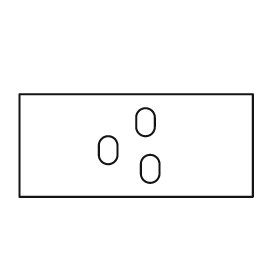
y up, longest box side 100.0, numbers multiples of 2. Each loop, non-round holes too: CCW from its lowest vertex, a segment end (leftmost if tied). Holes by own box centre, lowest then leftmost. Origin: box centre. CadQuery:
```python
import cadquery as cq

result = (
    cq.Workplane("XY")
    .moveTo(-50.0, -22.0)
    .lineTo(50.0, -22.0)
    .lineTo(50.0, 22.0)
    .lineTo(-50.0, 22.0)
    .close()
    .moveTo(2.0, -12.0)
    .threePointArc((6.0, -16.0), (10.0, -12.0))
    .lineTo(10.0, -8.0)
    .threePointArc((6.0, -4.0), (2.0, -8.0))
    .close()
    .moveTo(-16.0, -4.0)
    .threePointArc((-12.0, -8.0), (-8.0, -4.0))
    .lineTo(-8.0, 0.0)
    .threePointArc((-12.0, 4.0), (-16.0, 0.0))
    .close()
    .moveTo(0.0, 8.0)
    .threePointArc((4.0, 4.0), (8.0, 8.0))
    .lineTo(8.0, 12.0)
    .threePointArc((4.0, 16.0), (0.0, 12.0))
    .close()
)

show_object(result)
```